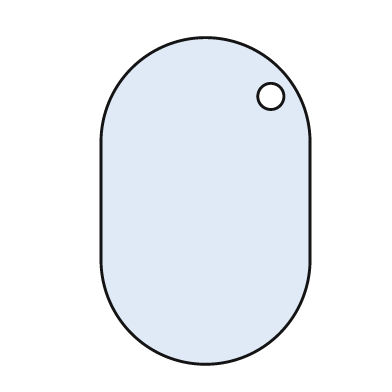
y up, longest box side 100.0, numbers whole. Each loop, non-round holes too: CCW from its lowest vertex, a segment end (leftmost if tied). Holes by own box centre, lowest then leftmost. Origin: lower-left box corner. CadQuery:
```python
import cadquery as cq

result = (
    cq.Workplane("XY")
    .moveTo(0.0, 32.0)
    .threePointArc((32.0, 0.0), (64.0, 32.0))
    .lineTo(64.0, 68.0)
    .threePointArc((32.0, 100.0), (0.0, 68.0))
    .close()
    .moveTo(52.0, 82.0)
    .circle(4.0)
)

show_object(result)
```